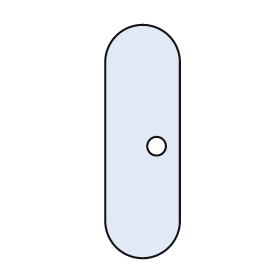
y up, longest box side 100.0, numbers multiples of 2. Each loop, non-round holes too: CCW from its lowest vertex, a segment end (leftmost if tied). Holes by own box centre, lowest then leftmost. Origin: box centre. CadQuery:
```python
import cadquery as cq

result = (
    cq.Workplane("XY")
    .moveTo(-16.0, -34.0)
    .threePointArc((0.0, -50.0), (16.0, -34.0))
    .lineTo(16.0, 34.0)
    .threePointArc((0.0, 50.0), (-16.0, 34.0))
    .close()
    .moveTo(6.0, -2.0)
    .circle(4.0)
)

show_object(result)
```